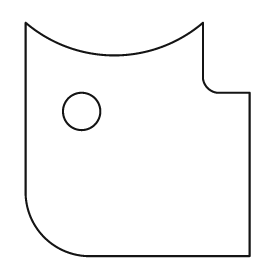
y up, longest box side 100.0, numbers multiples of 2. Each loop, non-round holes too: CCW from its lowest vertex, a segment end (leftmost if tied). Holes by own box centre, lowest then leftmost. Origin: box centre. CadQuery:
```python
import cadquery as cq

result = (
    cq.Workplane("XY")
    .moveTo(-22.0, -50.0)
    .lineTo(48.0, -50.0)
    .lineTo(48.0, 20.0)
    .lineTo(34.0, 20.0)
    .threePointArc((30.0, 22.0), (28.0, 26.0))
    .lineTo(28.0, 50.0)
    .threePointArc((-10.0, 36.0), (-48.0, 50.0))
    .lineTo(-48.0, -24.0)
    .threePointArc((-40.0, -42.0), (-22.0, -50.0))
    .close()
    .moveTo(-24.0, 12.0)
    .circle(8.0)
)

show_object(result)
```